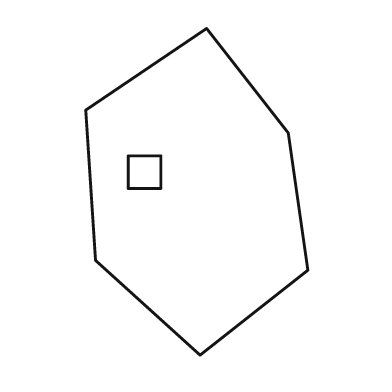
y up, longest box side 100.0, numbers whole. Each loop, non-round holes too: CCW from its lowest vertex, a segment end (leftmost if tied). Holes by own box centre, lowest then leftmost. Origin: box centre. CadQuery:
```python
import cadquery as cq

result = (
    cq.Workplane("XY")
    .moveTo(1.0, -50.0)
    .lineTo(34.0, -24.0)
    .lineTo(28.0, 18.0)
    .lineTo(3.0, 50.0)
    .lineTo(-34.0, 25.0)
    .lineTo(-31.0, -21.0)
    .close()
    .moveTo(-21.0, 1.0)
    .lineTo(-11.0, 1.0)
    .lineTo(-11.0, 11.0)
    .lineTo(-21.0, 11.0)
    .close()
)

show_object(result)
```